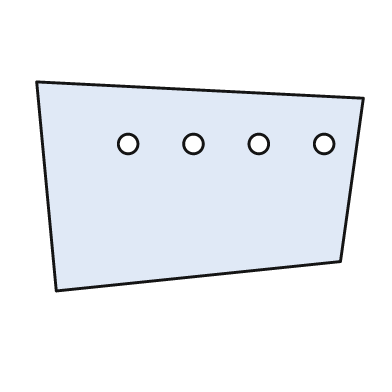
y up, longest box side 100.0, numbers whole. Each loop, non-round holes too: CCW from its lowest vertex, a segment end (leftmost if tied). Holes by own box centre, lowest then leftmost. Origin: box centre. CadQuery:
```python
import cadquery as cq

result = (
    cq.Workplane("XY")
    .moveTo(-44.0, -32.0)
    .lineTo(43.0, -23.0)
    .lineTo(50.0, 27.0)
    .lineTo(-50.0, 32.0)
    .close()
    .moveTo(-22.0, 13.0)
    .circle(3.0)
    .moveTo(-2.0, 13.0)
    .circle(3.0)
    .moveTo(18.0, 13.0)
    .circle(3.0)
    .moveTo(38.0, 13.0)
    .circle(3.0)
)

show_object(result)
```